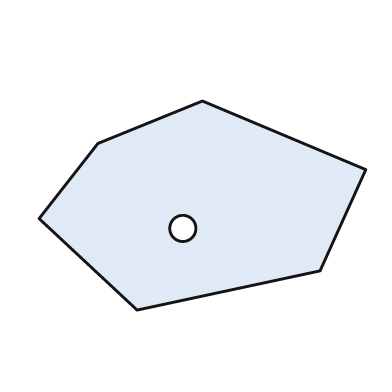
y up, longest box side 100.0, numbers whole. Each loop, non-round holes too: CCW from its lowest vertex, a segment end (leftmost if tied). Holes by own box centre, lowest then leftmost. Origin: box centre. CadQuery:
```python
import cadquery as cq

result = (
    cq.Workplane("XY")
    .moveTo(-20.0, -32.0)
    .lineTo(36.0, -20.0)
    .lineTo(50.0, 11.0)
    .lineTo(0.0, 32.0)
    .lineTo(-32.0, 19.0)
    .lineTo(-50.0, -4.0)
    .close()
    .moveTo(-6.0, -7.0)
    .circle(4.0)
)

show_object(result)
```